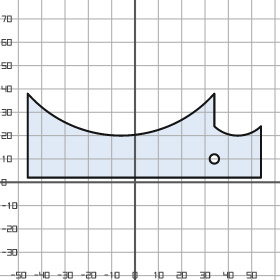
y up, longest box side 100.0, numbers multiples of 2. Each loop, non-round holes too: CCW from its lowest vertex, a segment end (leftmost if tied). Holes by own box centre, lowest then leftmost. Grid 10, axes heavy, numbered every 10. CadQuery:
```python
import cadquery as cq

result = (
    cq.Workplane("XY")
    .moveTo(-46.0, 2.0)
    .lineTo(54.0, 2.0)
    .lineTo(54.0, 24.0)
    .threePointArc((44.0, 20.0), (34.0, 24.0))
    .lineTo(34.0, 38.0)
    .threePointArc((-6.0, 20.0), (-46.0, 38.0))
    .close()
    .moveTo(34.0, 10.0)
    .circle(2.0)
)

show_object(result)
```